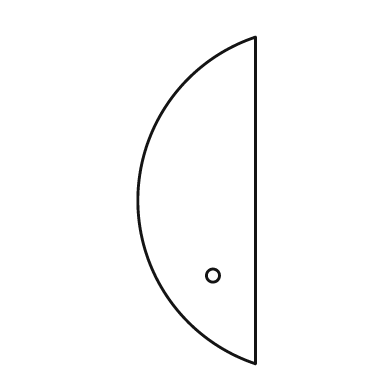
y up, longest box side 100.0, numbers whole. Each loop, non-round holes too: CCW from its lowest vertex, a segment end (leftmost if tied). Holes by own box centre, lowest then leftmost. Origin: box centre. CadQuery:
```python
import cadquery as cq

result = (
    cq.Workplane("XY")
    .moveTo(18.0, -50.0)
    .lineTo(18.0, 50.0)
    .threePointArc((-18.0, 0.0), (18.0, -50.0))
    .close()
    .moveTo(5.0, -23.0)
    .circle(2.0)
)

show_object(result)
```